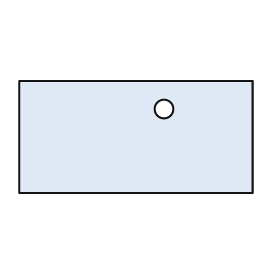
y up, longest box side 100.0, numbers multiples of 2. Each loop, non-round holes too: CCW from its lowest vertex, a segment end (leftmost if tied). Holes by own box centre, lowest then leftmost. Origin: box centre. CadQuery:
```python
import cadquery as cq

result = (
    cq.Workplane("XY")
    .moveTo(-50.0, -24.0)
    .lineTo(50.0, -24.0)
    .lineTo(50.0, 24.0)
    .lineTo(-50.0, 24.0)
    .close()
    .moveTo(12.0, 12.0)
    .circle(4.0)
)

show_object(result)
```